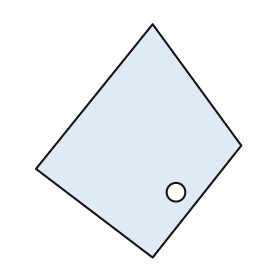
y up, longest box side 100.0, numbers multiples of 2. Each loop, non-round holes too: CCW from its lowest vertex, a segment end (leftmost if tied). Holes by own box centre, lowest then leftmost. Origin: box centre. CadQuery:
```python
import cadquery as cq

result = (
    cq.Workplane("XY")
    .moveTo(6.0, -50.0)
    .lineTo(44.0, -2.0)
    .lineTo(6.0, 50.0)
    .lineTo(-44.0, -12.0)
    .close()
    .moveTo(16.0, -22.0)
    .circle(4.0)
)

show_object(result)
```